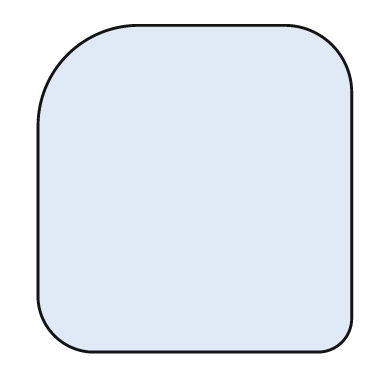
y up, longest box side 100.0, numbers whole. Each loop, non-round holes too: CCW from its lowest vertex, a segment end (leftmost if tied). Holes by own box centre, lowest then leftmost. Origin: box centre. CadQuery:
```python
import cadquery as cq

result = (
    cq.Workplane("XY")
    .moveTo(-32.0, -50.0)
    .lineTo(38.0, -50.0)
    .threePointArc((45.0, -47.0), (48.0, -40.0))
    .lineTo(48.0, 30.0)
    .threePointArc((42.0, 44.0), (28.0, 50.0))
    .lineTo(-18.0, 50.0)
    .threePointArc((-39.0, 41.0), (-48.0, 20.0))
    .lineTo(-48.0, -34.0)
    .threePointArc((-43.0, -45.0), (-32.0, -50.0))
    .close()
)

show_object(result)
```